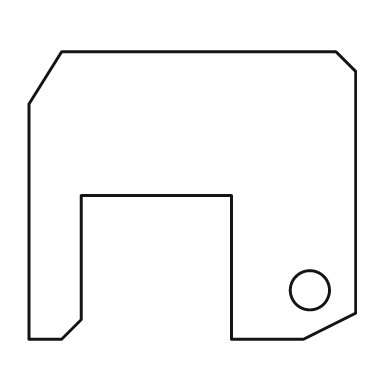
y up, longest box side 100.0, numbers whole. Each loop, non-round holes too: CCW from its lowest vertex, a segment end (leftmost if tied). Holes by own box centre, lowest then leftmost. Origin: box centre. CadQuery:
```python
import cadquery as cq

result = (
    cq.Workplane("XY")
    .moveTo(-50.0, -44.0)
    .lineTo(-40.0, -44.0)
    .lineTo(-34.0, -38.0)
    .lineTo(-34.0, 0.0)
    .lineTo(12.0, 0.0)
    .lineTo(12.0, -44.0)
    .lineTo(34.0, -44.0)
    .lineTo(50.0, -36.0)
    .lineTo(50.0, 38.0)
    .lineTo(44.0, 44.0)
    .lineTo(-40.0, 44.0)
    .lineTo(-50.0, 28.0)
    .close()
    .moveTo(36.0, -29.0)
    .circle(6.0)
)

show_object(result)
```